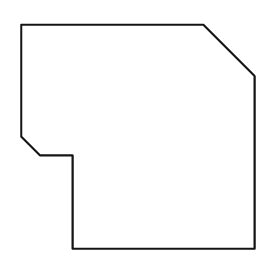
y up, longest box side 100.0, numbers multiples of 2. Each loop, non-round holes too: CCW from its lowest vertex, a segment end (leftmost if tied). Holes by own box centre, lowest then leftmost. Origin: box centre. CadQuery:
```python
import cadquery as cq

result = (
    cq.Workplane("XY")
    .moveTo(-28.0, -48.0)
    .lineTo(50.0, -48.0)
    .lineTo(50.0, 26.0)
    .lineTo(28.0, 48.0)
    .lineTo(-50.0, 48.0)
    .lineTo(-50.0, 0.0)
    .lineTo(-42.0, -8.0)
    .lineTo(-28.0, -8.0)
    .close()
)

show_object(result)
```